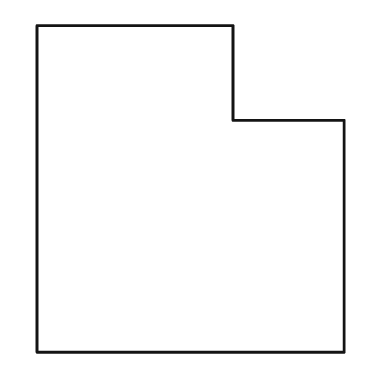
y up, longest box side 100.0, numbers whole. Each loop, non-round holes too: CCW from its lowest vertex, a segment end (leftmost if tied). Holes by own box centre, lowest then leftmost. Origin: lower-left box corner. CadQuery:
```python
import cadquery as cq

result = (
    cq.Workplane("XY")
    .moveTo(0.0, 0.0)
    .lineTo(94.0, 0.0)
    .lineTo(94.0, 71.0)
    .lineTo(60.0, 71.0)
    .lineTo(60.0, 100.0)
    .lineTo(0.0, 100.0)
    .close()
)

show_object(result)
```